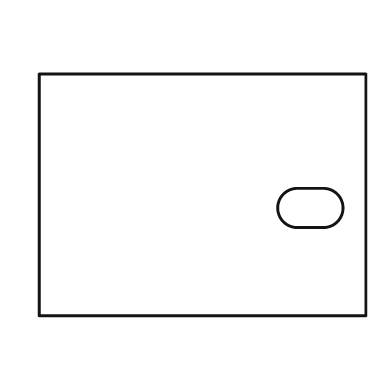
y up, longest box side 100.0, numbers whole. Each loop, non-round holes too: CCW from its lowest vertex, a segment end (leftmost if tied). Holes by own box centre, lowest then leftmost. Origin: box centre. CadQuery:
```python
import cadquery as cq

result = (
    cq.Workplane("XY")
    .moveTo(-50.0, -37.0)
    .lineTo(50.0, -37.0)
    .lineTo(50.0, 37.0)
    .lineTo(-50.0, 37.0)
    .close()
    .moveTo(29.0, -10.0)
    .lineTo(37.0, -10.0)
    .threePointArc((43.0, -4.0), (37.0, 2.0))
    .lineTo(29.0, 2.0)
    .threePointArc((23.0, -4.0), (29.0, -10.0))
    .close()
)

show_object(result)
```